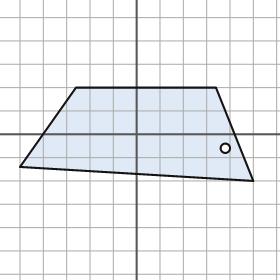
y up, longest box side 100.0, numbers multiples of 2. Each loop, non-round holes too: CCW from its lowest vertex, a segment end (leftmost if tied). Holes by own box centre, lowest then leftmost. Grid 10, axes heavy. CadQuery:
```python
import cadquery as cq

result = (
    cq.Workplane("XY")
    .moveTo(50.0, -20.0)
    .lineTo(34.0, 20.0)
    .lineTo(-26.0, 20.0)
    .lineTo(-50.0, -14.0)
    .close()
    .moveTo(38.0, -6.0)
    .circle(2.0)
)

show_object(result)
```